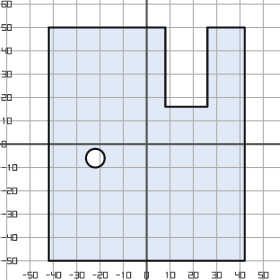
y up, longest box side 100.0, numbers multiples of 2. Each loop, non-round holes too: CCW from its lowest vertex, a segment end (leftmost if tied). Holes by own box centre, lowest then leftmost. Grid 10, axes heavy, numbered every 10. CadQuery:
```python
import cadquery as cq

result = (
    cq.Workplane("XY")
    .moveTo(-42.0, -50.0)
    .lineTo(42.0, -50.0)
    .lineTo(42.0, 50.0)
    .lineTo(26.0, 50.0)
    .lineTo(26.0, 16.0)
    .lineTo(8.0, 16.0)
    .lineTo(8.0, 50.0)
    .lineTo(-42.0, 50.0)
    .close()
    .moveTo(-22.0, -6.0)
    .circle(4.0)
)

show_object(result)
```